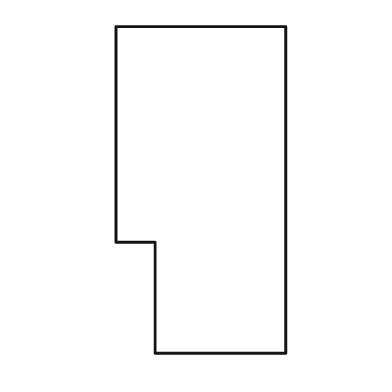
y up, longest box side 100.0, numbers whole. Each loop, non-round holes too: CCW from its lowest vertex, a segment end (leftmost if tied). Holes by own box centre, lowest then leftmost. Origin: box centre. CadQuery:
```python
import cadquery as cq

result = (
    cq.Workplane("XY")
    .moveTo(-14.0, -50.0)
    .lineTo(26.0, -50.0)
    .lineTo(26.0, 50.0)
    .lineTo(-26.0, 50.0)
    .lineTo(-26.0, -16.0)
    .lineTo(-14.0, -16.0)
    .close()
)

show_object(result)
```